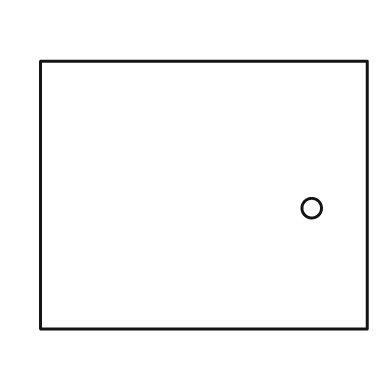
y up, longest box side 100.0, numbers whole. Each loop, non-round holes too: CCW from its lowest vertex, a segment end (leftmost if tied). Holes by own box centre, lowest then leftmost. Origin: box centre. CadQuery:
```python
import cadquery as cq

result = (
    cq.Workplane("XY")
    .moveTo(-50.0, -41.0)
    .lineTo(50.0, -41.0)
    .lineTo(50.0, 41.0)
    .lineTo(-50.0, 41.0)
    .close()
    .moveTo(33.0, -4.0)
    .circle(3.0)
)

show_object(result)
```